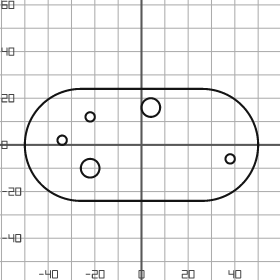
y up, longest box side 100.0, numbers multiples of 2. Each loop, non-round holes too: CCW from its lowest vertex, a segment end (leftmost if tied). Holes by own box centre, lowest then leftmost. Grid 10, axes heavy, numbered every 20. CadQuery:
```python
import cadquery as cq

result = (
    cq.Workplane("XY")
    .moveTo(-26.0, -24.0)
    .lineTo(26.0, -24.0)
    .threePointArc((50.0, 0.0), (26.0, 24.0))
    .lineTo(-26.0, 24.0)
    .threePointArc((-50.0, 0.0), (-26.0, -24.0))
    .close()
    .moveTo(-22.0, -10.0)
    .circle(4.0)
    .moveTo(38.0, -6.0)
    .circle(2.0)
    .moveTo(-34.0, 2.0)
    .circle(2.0)
    .moveTo(-22.0, 12.0)
    .circle(2.0)
    .moveTo(4.0, 16.0)
    .circle(4.0)
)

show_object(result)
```